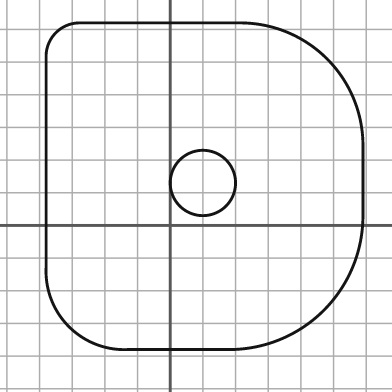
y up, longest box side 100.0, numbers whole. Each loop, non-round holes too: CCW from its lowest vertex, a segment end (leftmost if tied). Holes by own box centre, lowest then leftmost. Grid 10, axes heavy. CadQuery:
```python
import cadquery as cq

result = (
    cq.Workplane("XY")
    .moveTo(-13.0, -38.0)
    .lineTo(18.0, -38.0)
    .threePointArc((47.0, -26.0), (59.0, 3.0))
    .lineTo(59.0, 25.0)
    .threePointArc((48.0, 51.0), (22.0, 62.0))
    .lineTo(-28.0, 62.0)
    .threePointArc((-35.0, 59.0), (-38.0, 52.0))
    .lineTo(-38.0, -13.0)
    .threePointArc((-31.0, -31.0), (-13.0, -38.0))
    .close()
    .moveTo(10.0, 13.0)
    .circle(10.0)
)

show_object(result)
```